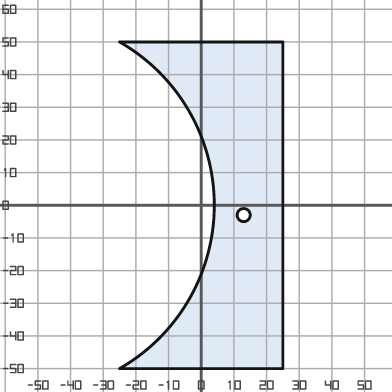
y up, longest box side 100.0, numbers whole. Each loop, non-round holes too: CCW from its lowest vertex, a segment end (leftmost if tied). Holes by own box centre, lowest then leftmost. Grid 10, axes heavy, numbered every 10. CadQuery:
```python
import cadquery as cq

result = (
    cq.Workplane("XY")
    .moveTo(-25.0, -50.0)
    .lineTo(25.0, -50.0)
    .lineTo(25.0, 50.0)
    .lineTo(-25.0, 50.0)
    .threePointArc((4.0, 0.0), (-25.0, -50.0))
    .close()
    .moveTo(13.0, -3.0)
    .circle(2.0)
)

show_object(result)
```